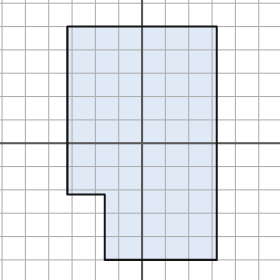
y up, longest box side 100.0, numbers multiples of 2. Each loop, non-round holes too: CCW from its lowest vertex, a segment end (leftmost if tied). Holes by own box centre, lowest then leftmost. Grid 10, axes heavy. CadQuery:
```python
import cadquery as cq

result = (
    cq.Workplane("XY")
    .moveTo(-16.0, -50.0)
    .lineTo(32.0, -50.0)
    .lineTo(32.0, 50.0)
    .lineTo(-32.0, 50.0)
    .lineTo(-32.0, -22.0)
    .lineTo(-16.0, -22.0)
    .close()
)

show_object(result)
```